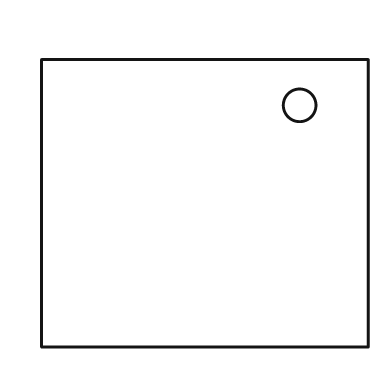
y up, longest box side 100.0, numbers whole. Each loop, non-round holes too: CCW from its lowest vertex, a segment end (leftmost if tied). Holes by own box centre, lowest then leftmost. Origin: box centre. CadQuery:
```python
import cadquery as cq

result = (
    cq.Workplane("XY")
    .moveTo(-50.0, -44.0)
    .lineTo(50.0, -44.0)
    .lineTo(50.0, 44.0)
    .lineTo(-50.0, 44.0)
    .close()
    .moveTo(29.0, 30.0)
    .circle(5.0)
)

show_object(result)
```